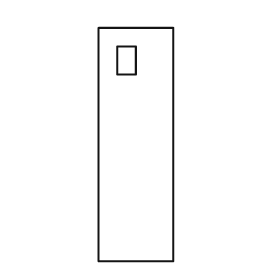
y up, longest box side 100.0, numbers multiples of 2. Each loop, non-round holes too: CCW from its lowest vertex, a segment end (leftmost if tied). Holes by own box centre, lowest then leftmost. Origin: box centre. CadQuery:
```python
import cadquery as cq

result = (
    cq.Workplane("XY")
    .moveTo(-16.0, -50.0)
    .lineTo(16.0, -50.0)
    .lineTo(16.0, 50.0)
    .lineTo(-16.0, 50.0)
    .close()
    .moveTo(-8.0, 30.0)
    .lineTo(0.0, 30.0)
    .lineTo(0.0, 42.0)
    .lineTo(-8.0, 42.0)
    .close()
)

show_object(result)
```